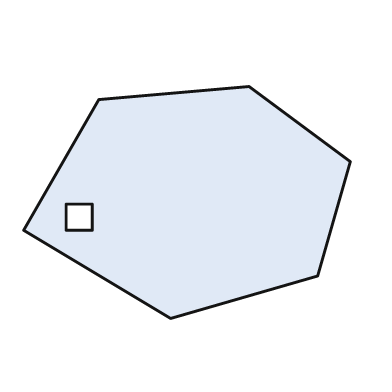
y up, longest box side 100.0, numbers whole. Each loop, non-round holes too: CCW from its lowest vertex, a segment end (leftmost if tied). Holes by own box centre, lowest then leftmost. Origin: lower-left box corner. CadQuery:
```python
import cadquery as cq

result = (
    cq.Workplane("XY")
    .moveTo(45.0, 0.0)
    .lineTo(90.0, 13.0)
    .lineTo(100.0, 48.0)
    .lineTo(69.0, 71.0)
    .lineTo(23.0, 67.0)
    .lineTo(0.0, 27.0)
    .close()
    .moveTo(13.0, 27.0)
    .lineTo(21.0, 27.0)
    .lineTo(21.0, 35.0)
    .lineTo(13.0, 35.0)
    .close()
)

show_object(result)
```